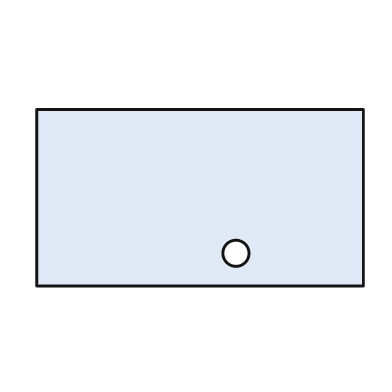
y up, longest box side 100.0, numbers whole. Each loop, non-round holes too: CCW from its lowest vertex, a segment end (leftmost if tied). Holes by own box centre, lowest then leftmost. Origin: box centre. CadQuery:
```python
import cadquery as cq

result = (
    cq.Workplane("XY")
    .moveTo(-50.0, -27.0)
    .lineTo(50.0, -27.0)
    .lineTo(50.0, 27.0)
    .lineTo(-50.0, 27.0)
    .close()
    .moveTo(11.0, -17.0)
    .circle(4.0)
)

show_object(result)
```